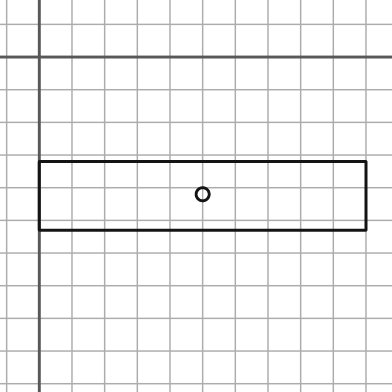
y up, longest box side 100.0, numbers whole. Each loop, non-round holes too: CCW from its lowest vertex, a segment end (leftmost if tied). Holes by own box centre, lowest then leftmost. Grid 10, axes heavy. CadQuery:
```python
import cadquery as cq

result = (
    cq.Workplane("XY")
    .moveTo(0.0, -53.0)
    .lineTo(100.0, -53.0)
    .lineTo(100.0, -32.0)
    .lineTo(0.0, -32.0)
    .close()
    .moveTo(50.0, -42.0)
    .circle(2.0)
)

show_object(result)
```